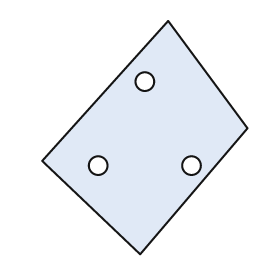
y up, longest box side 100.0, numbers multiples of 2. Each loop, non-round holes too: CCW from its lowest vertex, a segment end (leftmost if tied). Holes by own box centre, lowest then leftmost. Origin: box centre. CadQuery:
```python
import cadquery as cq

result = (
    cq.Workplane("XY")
    .moveTo(-2.0, -50.0)
    .lineTo(44.0, 4.0)
    .lineTo(10.0, 50.0)
    .lineTo(-44.0, -10.0)
    .close()
    .moveTo(-20.0, -12.0)
    .circle(4.0)
    .moveTo(20.0, -12.0)
    .circle(4.0)
    .moveTo(0.0, 24.0)
    .circle(4.0)
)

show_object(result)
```